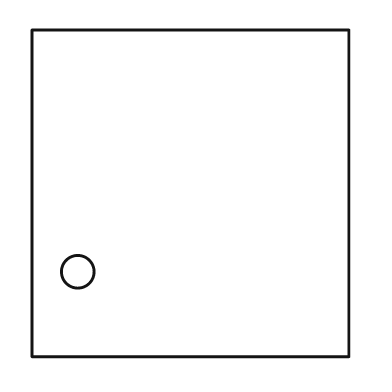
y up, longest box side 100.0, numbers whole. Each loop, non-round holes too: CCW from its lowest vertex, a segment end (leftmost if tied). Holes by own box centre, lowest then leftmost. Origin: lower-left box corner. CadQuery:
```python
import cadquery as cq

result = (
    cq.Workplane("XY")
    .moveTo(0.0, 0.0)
    .lineTo(97.0, 0.0)
    .lineTo(97.0, 100.0)
    .lineTo(0.0, 100.0)
    .close()
    .moveTo(14.0, 26.0)
    .circle(5.0)
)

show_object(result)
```